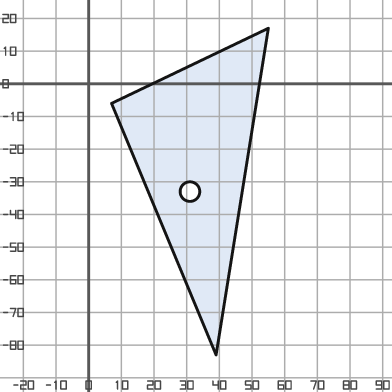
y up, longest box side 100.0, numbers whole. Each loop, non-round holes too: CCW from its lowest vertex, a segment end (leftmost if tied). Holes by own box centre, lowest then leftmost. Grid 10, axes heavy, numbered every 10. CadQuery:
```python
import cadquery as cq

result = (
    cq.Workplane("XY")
    .moveTo(39.0, -83.0)
    .lineTo(55.0, 17.0)
    .lineTo(7.0, -6.0)
    .close()
    .moveTo(31.0, -33.0)
    .circle(3.0)
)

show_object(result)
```